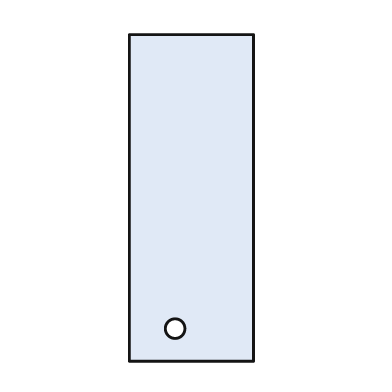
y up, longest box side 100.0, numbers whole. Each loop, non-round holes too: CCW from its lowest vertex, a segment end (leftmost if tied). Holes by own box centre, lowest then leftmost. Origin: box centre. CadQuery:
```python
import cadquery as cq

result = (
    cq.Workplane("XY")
    .moveTo(-19.0, -50.0)
    .lineTo(19.0, -50.0)
    .lineTo(19.0, 50.0)
    .lineTo(-19.0, 50.0)
    .close()
    .moveTo(-5.0, -40.0)
    .circle(3.0)
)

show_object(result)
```